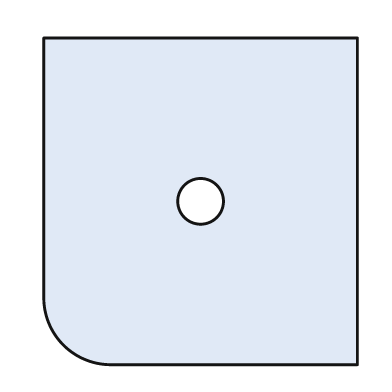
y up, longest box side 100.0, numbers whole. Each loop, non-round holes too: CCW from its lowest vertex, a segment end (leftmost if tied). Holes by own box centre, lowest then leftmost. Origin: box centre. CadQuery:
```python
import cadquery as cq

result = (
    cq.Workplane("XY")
    .moveTo(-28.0, -50.0)
    .lineTo(48.0, -50.0)
    .lineTo(48.0, 50.0)
    .lineTo(-48.0, 50.0)
    .lineTo(-48.0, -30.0)
    .threePointArc((-42.0, -44.0), (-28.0, -50.0))
    .close()
    .moveTo(0.0, 0.0)
    .circle(7.0)
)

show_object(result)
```